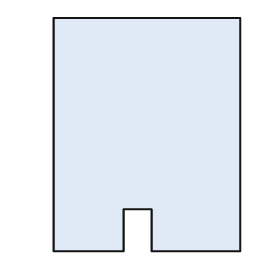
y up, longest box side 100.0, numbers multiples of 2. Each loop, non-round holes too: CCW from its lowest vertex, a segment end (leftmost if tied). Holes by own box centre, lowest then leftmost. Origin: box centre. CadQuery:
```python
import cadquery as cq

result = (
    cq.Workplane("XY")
    .moveTo(-40.0, -50.0)
    .lineTo(-10.0, -50.0)
    .lineTo(-10.0, -32.0)
    .lineTo(2.0, -32.0)
    .lineTo(2.0, -50.0)
    .lineTo(40.0, -50.0)
    .lineTo(40.0, 50.0)
    .lineTo(-40.0, 50.0)
    .close()
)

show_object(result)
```